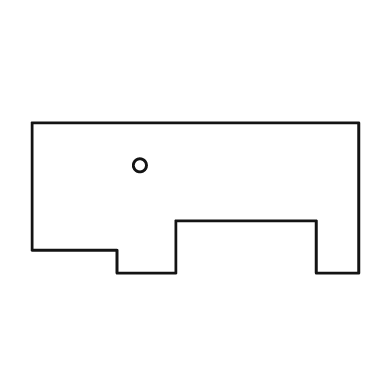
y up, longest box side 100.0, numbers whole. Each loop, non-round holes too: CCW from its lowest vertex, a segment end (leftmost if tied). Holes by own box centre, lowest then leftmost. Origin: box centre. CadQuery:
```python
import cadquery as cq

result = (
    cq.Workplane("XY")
    .moveTo(-24.0, -23.0)
    .lineTo(-6.0, -23.0)
    .lineTo(-6.0, -7.0)
    .lineTo(37.0, -7.0)
    .lineTo(37.0, -23.0)
    .lineTo(50.0, -23.0)
    .lineTo(50.0, 23.0)
    .lineTo(-50.0, 23.0)
    .lineTo(-50.0, -16.0)
    .lineTo(-24.0, -16.0)
    .close()
    .moveTo(-17.0, 10.0)
    .circle(2.0)
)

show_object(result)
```